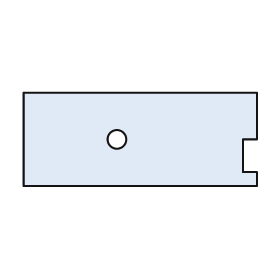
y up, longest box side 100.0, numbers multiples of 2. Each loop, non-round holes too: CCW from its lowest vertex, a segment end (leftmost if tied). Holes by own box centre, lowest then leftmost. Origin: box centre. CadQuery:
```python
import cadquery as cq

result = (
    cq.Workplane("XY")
    .moveTo(-50.0, -20.0)
    .lineTo(50.0, -20.0)
    .lineTo(50.0, -14.0)
    .lineTo(44.0, -14.0)
    .lineTo(44.0, 0.0)
    .lineTo(50.0, 0.0)
    .lineTo(50.0, 20.0)
    .lineTo(-50.0, 20.0)
    .close()
    .moveTo(-10.0, 0.0)
    .circle(4.0)
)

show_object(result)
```